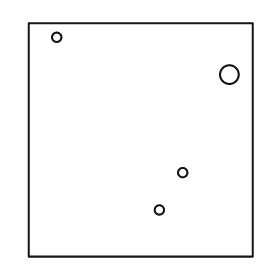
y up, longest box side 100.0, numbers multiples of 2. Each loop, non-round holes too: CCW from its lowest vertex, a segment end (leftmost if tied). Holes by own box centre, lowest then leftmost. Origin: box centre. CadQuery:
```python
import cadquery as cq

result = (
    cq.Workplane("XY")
    .moveTo(-48.0, -50.0)
    .lineTo(48.0, -50.0)
    .lineTo(48.0, 50.0)
    .lineTo(-48.0, 50.0)
    .close()
    .moveTo(8.0, -30.0)
    .circle(2.0)
    .moveTo(18.0, -14.0)
    .circle(2.0)
    .moveTo(38.0, 28.0)
    .circle(4.0)
    .moveTo(-36.0, 44.0)
    .circle(2.0)
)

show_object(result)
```